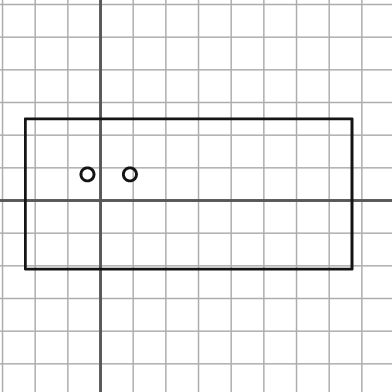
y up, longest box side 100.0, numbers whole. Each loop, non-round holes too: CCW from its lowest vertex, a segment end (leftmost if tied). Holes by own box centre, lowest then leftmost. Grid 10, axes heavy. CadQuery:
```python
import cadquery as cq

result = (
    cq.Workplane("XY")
    .moveTo(-23.0, -21.0)
    .lineTo(77.0, -21.0)
    .lineTo(77.0, 25.0)
    .lineTo(-23.0, 25.0)
    .close()
    .moveTo(-4.0, 8.0)
    .circle(2.0)
    .moveTo(9.0, 8.0)
    .circle(2.0)
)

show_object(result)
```